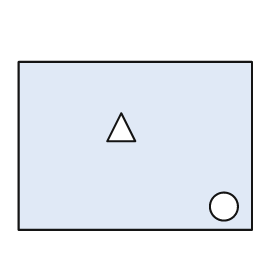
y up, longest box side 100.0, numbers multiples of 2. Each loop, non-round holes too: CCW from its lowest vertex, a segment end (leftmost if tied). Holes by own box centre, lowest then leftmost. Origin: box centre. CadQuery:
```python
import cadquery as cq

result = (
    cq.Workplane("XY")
    .moveTo(-50.0, -36.0)
    .lineTo(50.0, -36.0)
    .lineTo(50.0, 36.0)
    .lineTo(-50.0, 36.0)
    .close()
    .moveTo(38.0, -26.0)
    .circle(6.0)
    .moveTo(-12.0, 2.0)
    .lineTo(0.0, 2.0)
    .lineTo(-6.0, 14.0)
    .close()
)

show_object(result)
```